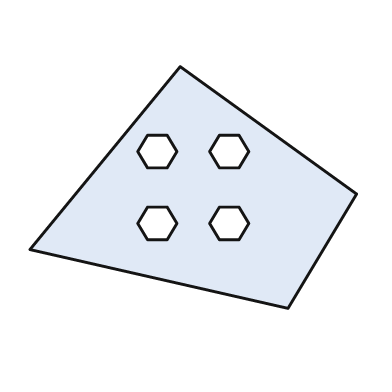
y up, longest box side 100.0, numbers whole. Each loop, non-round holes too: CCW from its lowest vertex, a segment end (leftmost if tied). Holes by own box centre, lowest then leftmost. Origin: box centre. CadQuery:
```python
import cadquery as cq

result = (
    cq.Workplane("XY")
    .moveTo(29.0, -37.0)
    .lineTo(50.0, -2.0)
    .lineTo(-4.0, 37.0)
    .lineTo(-50.0, -19.0)
    .close()
    .moveTo(-14.0, -16.0)
    .lineTo(-8.0, -16.0)
    .lineTo(-5.0, -11.0)
    .lineTo(-8.0, -6.0)
    .lineTo(-14.0, -6.0)
    .lineTo(-17.0, -11.0)
    .close()
    .moveTo(8.0, -16.0)
    .lineTo(14.0, -16.0)
    .lineTo(17.0, -11.0)
    .lineTo(14.0, -6.0)
    .lineTo(8.0, -6.0)
    .lineTo(5.0, -11.0)
    .close()
    .moveTo(-14.0, 6.0)
    .lineTo(-8.0, 6.0)
    .lineTo(-5.0, 11.0)
    .lineTo(-8.0, 16.0)
    .lineTo(-14.0, 16.0)
    .lineTo(-17.0, 11.0)
    .close()
    .moveTo(8.0, 6.0)
    .lineTo(14.0, 6.0)
    .lineTo(17.0, 11.0)
    .lineTo(14.0, 16.0)
    .lineTo(8.0, 16.0)
    .lineTo(5.0, 11.0)
    .close()
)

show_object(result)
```